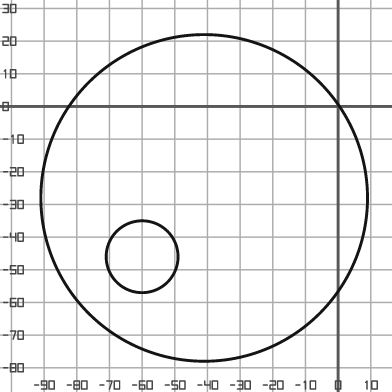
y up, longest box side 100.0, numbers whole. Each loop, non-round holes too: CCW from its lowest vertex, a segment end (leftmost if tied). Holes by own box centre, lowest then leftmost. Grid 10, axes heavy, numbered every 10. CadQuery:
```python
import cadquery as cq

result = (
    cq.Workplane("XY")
    .moveTo(-41.0, -28.0)
    .circle(50.0)
    .moveTo(-60.0, -46.0)
    .circle(11.0)
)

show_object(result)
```